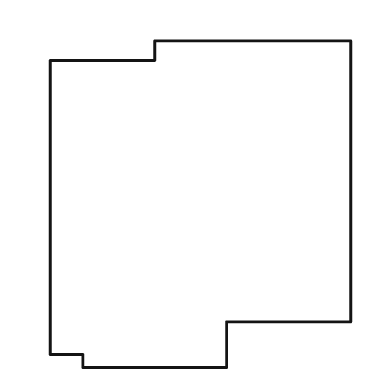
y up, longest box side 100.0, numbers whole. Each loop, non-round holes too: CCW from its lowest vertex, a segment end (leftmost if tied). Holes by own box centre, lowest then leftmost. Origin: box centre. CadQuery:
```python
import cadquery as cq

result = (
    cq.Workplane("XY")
    .moveTo(-36.0, -50.0)
    .lineTo(8.0, -50.0)
    .lineTo(8.0, -36.0)
    .lineTo(46.0, -36.0)
    .lineTo(46.0, 50.0)
    .lineTo(-14.0, 50.0)
    .lineTo(-14.0, 44.0)
    .lineTo(-46.0, 44.0)
    .lineTo(-46.0, -46.0)
    .lineTo(-36.0, -46.0)
    .close()
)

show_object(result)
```